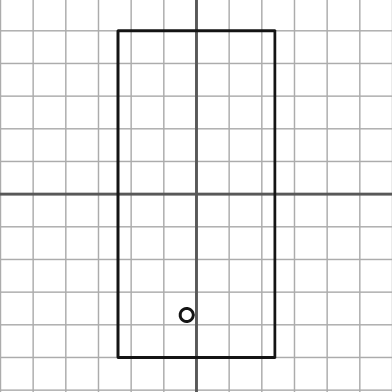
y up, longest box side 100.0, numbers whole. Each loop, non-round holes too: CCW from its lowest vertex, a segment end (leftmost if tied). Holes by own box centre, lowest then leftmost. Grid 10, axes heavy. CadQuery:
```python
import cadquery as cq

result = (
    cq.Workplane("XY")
    .moveTo(-24.0, -50.0)
    .lineTo(24.0, -50.0)
    .lineTo(24.0, 50.0)
    .lineTo(-24.0, 50.0)
    .close()
    .moveTo(-3.0, -37.0)
    .circle(2.0)
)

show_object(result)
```